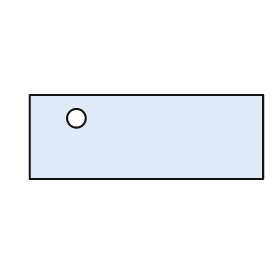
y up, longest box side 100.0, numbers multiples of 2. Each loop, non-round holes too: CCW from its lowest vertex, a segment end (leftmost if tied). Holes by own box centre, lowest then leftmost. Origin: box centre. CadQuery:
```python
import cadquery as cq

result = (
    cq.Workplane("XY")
    .moveTo(-50.0, -18.0)
    .lineTo(50.0, -18.0)
    .lineTo(50.0, 18.0)
    .lineTo(-50.0, 18.0)
    .close()
    .moveTo(-30.0, 8.0)
    .circle(4.0)
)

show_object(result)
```